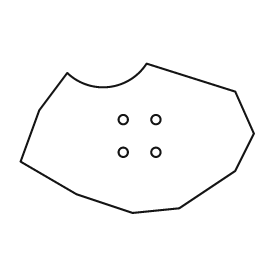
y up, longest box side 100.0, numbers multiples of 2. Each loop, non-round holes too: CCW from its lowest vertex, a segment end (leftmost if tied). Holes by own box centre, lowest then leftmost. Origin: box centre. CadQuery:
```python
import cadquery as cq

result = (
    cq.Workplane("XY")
    .moveTo(-2.0, -32.0)
    .lineTo(18.0, -30.0)
    .lineTo(42.0, -14.0)
    .lineTo(50.0, 2.0)
    .lineTo(42.0, 20.0)
    .lineTo(4.0, 32.0)
    .threePointArc((-12.0, 22.0), (-30.0, 28.0))
    .lineTo(-42.0, 12.0)
    .lineTo(-50.0, -10.0)
    .lineTo(-26.0, -24.0)
    .close()
    .moveTo(-6.0, -6.0)
    .circle(2.0)
    .moveTo(8.0, -6.0)
    .circle(2.0)
    .moveTo(-6.0, 8.0)
    .circle(2.0)
    .moveTo(8.0, 8.0)
    .circle(2.0)
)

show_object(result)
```